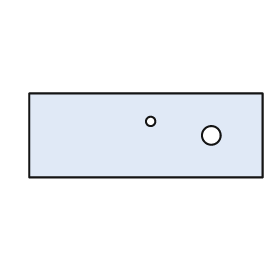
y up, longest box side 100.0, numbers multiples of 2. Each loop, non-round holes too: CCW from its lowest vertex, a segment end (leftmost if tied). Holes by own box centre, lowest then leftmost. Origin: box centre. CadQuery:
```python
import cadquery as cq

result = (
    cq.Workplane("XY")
    .moveTo(-50.0, -18.0)
    .lineTo(50.0, -18.0)
    .lineTo(50.0, 18.0)
    .lineTo(-50.0, 18.0)
    .close()
    .moveTo(28.0, 0.0)
    .circle(4.0)
    .moveTo(2.0, 6.0)
    .circle(2.0)
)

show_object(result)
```